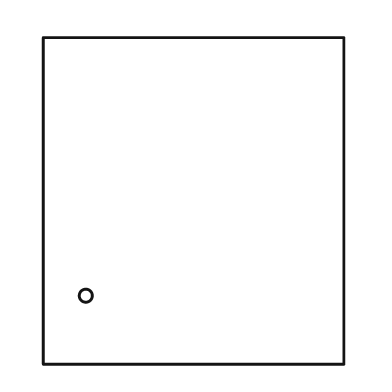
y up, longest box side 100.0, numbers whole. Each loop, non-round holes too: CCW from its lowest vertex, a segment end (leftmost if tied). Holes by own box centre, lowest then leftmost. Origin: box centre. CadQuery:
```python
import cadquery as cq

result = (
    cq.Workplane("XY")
    .moveTo(-46.0, -50.0)
    .lineTo(46.0, -50.0)
    .lineTo(46.0, 50.0)
    .lineTo(-46.0, 50.0)
    .close()
    .moveTo(-33.0, -29.0)
    .circle(2.0)
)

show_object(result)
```